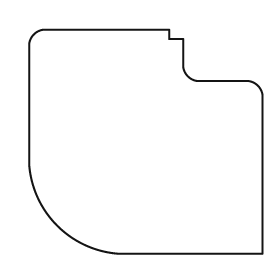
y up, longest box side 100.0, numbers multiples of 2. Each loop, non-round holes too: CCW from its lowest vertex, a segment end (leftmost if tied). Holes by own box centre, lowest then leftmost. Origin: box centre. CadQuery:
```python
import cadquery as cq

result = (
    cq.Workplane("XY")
    .moveTo(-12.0, -48.0)
    .lineTo(50.0, -48.0)
    .lineTo(50.0, 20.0)
    .threePointArc((48.0, 24.0), (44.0, 26.0))
    .lineTo(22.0, 26.0)
    .threePointArc((18.0, 28.0), (16.0, 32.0))
    .lineTo(16.0, 44.0)
    .lineTo(10.0, 44.0)
    .lineTo(10.0, 48.0)
    .lineTo(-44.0, 48.0)
    .threePointArc((-48.0, 46.0), (-50.0, 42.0))
    .lineTo(-50.0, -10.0)
    .threePointArc((-38.0, -36.0), (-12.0, -48.0))
    .close()
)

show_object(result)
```